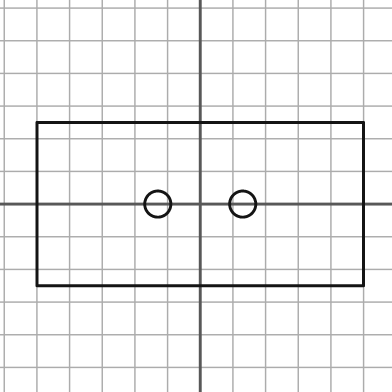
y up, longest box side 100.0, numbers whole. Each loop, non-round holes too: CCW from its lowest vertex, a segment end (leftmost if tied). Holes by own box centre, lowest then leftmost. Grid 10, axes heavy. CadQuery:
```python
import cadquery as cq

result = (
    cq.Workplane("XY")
    .moveTo(-50.0, -25.0)
    .lineTo(50.0, -25.0)
    .lineTo(50.0, 25.0)
    .lineTo(-50.0, 25.0)
    .close()
    .moveTo(-13.0, 0.0)
    .circle(4.0)
    .moveTo(13.0, 0.0)
    .circle(4.0)
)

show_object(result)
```